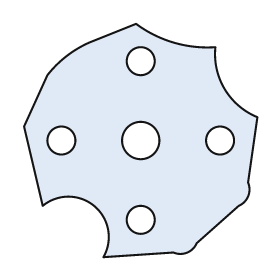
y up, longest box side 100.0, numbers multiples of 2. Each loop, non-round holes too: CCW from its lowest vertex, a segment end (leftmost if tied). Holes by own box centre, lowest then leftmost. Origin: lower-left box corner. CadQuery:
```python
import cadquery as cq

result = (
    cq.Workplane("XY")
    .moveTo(34.0, 0.0)
    .lineTo(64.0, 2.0)
    .threePointArc((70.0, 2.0), (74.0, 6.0))
    .lineTo(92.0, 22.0)
    .threePointArc((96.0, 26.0), (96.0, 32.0))
    .lineTo(100.0, 60.0)
    .threePointArc((86.0, 72.0), (82.0, 90.0))
    .threePointArc((64.0, 92.0), (48.0, 100.0))
    .lineTo(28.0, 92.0)
    .threePointArc((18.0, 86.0), (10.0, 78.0))
    .lineTo(0.0, 56.0)
    .lineTo(8.0, 22.0)
    .threePointArc((30.0, 22.0), (34.0, 0.0))
    .close()
    .moveTo(50.0, 16.0)
    .circle(6.0)
    .moveTo(16.0, 50.0)
    .circle(6.0)
    .moveTo(50.0, 50.0)
    .circle(8.0)
    .moveTo(84.0, 50.0)
    .circle(6.0)
    .moveTo(50.0, 84.0)
    .circle(6.0)
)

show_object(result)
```